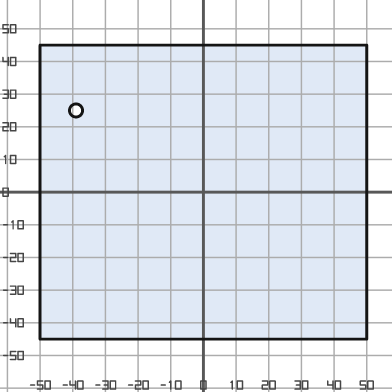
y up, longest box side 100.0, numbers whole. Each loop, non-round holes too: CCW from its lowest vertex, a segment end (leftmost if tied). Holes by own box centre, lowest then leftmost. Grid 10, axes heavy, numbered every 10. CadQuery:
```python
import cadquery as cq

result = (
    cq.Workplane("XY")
    .moveTo(-50.0, -45.0)
    .lineTo(50.0, -45.0)
    .lineTo(50.0, 45.0)
    .lineTo(-50.0, 45.0)
    .close()
    .moveTo(-39.0, 25.0)
    .circle(2.0)
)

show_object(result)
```